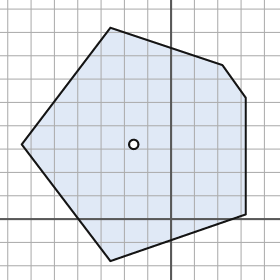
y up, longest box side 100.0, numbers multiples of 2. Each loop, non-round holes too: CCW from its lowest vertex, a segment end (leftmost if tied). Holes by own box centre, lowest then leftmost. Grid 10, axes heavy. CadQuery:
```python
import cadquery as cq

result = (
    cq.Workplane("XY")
    .moveTo(-26.0, -18.0)
    .lineTo(32.0, 2.0)
    .lineTo(32.0, 52.0)
    .lineTo(22.0, 66.0)
    .lineTo(-26.0, 82.0)
    .lineTo(-64.0, 32.0)
    .close()
    .moveTo(-16.0, 32.0)
    .circle(2.0)
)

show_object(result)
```